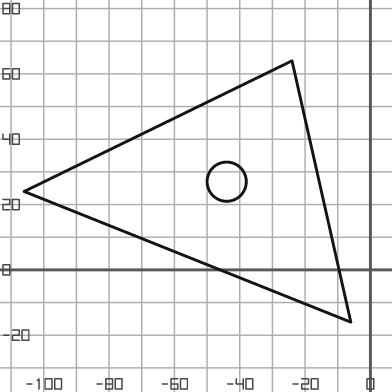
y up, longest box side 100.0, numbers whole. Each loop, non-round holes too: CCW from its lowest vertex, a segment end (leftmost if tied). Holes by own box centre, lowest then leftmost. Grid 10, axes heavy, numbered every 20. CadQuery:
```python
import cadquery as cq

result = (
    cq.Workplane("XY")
    .moveTo(-6.0, -16.0)
    .lineTo(-24.0, 64.0)
    .lineTo(-106.0, 24.0)
    .close()
    .moveTo(-44.0, 27.0)
    .circle(6.0)
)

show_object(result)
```